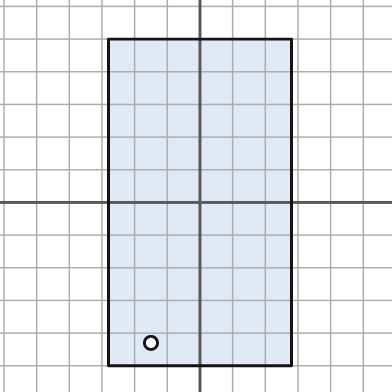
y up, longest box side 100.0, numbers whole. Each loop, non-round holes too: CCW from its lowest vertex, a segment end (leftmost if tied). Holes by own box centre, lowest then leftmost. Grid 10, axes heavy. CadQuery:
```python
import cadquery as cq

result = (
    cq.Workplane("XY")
    .moveTo(-28.0, -50.0)
    .lineTo(28.0, -50.0)
    .lineTo(28.0, 50.0)
    .lineTo(-28.0, 50.0)
    .close()
    .moveTo(-15.0, -43.0)
    .circle(2.0)
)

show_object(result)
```